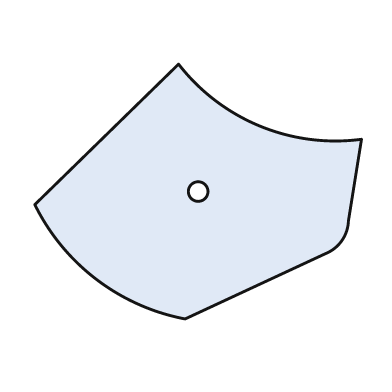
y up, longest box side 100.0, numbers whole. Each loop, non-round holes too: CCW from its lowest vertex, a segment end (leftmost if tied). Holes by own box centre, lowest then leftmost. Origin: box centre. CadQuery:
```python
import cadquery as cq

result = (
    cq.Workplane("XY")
    .moveTo(-4.0, -39.0)
    .lineTo(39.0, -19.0)
    .threePointArc((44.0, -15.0), (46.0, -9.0))
    .lineTo(50.0, 16.0)
    .threePointArc((19.0, 20.0), (-6.0, 39.0))
    .lineTo(-50.0, -4.0)
    .threePointArc((-31.0, -27.0), (-4.0, -39.0))
    .close()
    .moveTo(0.0, 0.0)
    .circle(3.0)
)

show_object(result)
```